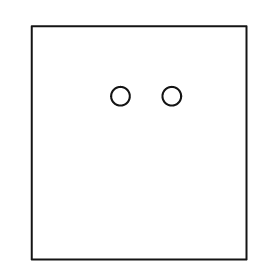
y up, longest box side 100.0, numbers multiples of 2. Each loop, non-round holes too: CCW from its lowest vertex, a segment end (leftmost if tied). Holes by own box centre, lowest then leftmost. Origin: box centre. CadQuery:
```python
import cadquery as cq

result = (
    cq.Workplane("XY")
    .moveTo(-46.0, -50.0)
    .lineTo(46.0, -50.0)
    .lineTo(46.0, 50.0)
    .lineTo(-46.0, 50.0)
    .close()
    .moveTo(-8.0, 20.0)
    .circle(4.0)
    .moveTo(14.0, 20.0)
    .circle(4.0)
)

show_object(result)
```